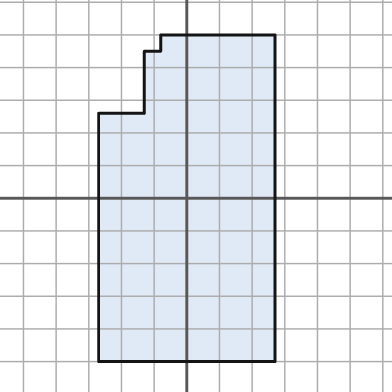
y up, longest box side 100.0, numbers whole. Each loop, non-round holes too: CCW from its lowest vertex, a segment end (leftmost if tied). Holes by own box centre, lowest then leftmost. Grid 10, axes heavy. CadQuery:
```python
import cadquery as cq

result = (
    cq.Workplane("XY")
    .moveTo(-27.0, -50.0)
    .lineTo(27.0, -50.0)
    .lineTo(27.0, 50.0)
    .lineTo(-8.0, 50.0)
    .lineTo(-8.0, 45.0)
    .lineTo(-13.0, 45.0)
    .lineTo(-13.0, 26.0)
    .lineTo(-27.0, 26.0)
    .close()
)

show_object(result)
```